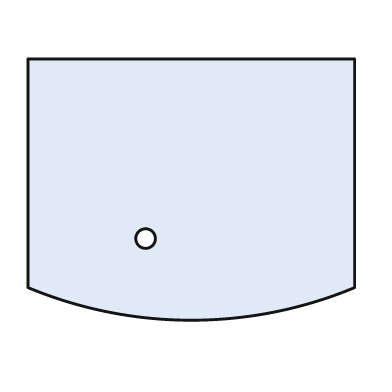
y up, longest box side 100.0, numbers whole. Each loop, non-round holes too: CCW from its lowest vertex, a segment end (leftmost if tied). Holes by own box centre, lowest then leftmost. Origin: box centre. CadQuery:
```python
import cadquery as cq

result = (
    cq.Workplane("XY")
    .moveTo(-50.0, -30.0)
    .threePointArc((0.0, -40.0), (50.0, -30.0))
    .lineTo(50.0, 40.0)
    .lineTo(-50.0, 40.0)
    .close()
    .moveTo(-14.0, -15.0)
    .circle(3.0)
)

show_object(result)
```